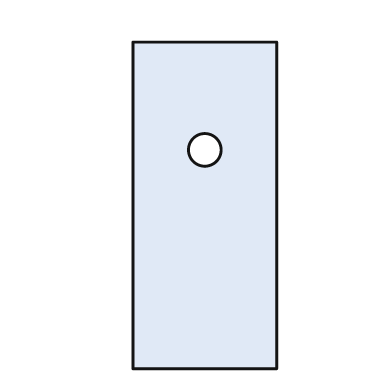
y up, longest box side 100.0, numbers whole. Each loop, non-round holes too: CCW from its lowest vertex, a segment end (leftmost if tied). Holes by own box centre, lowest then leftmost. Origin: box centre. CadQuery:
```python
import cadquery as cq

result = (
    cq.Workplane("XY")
    .moveTo(-22.0, -50.0)
    .lineTo(22.0, -50.0)
    .lineTo(22.0, 50.0)
    .lineTo(-22.0, 50.0)
    .close()
    .moveTo(0.0, 17.0)
    .circle(5.0)
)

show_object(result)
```